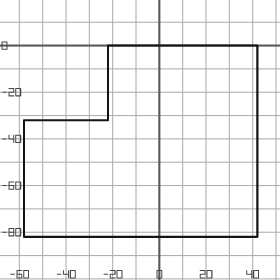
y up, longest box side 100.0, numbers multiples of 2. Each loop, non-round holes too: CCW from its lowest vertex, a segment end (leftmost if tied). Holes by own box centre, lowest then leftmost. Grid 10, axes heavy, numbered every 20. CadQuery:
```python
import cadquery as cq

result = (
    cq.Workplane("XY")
    .moveTo(-58.0, -82.0)
    .lineTo(42.0, -82.0)
    .lineTo(42.0, 0.0)
    .lineTo(-22.0, 0.0)
    .lineTo(-22.0, -32.0)
    .lineTo(-58.0, -32.0)
    .close()
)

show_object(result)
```